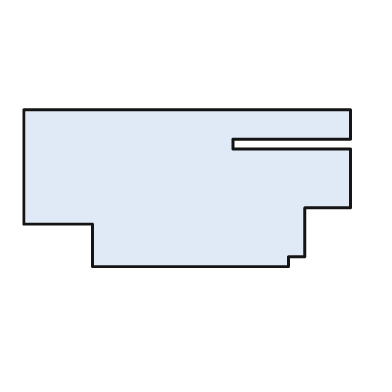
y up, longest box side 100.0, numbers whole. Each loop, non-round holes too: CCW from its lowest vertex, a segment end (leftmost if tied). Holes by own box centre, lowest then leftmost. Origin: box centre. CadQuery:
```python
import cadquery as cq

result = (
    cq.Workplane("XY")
    .moveTo(-29.0, -24.0)
    .lineTo(31.0, -24.0)
    .lineTo(31.0, -21.0)
    .lineTo(36.0, -21.0)
    .lineTo(36.0, -6.0)
    .lineTo(50.0, -6.0)
    .lineTo(50.0, 12.0)
    .lineTo(14.0, 12.0)
    .lineTo(14.0, 15.0)
    .lineTo(50.0, 15.0)
    .lineTo(50.0, 24.0)
    .lineTo(-50.0, 24.0)
    .lineTo(-50.0, -11.0)
    .lineTo(-29.0, -11.0)
    .close()
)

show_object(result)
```